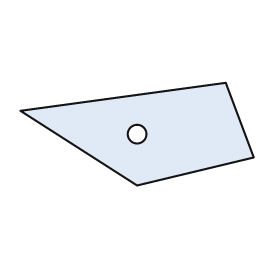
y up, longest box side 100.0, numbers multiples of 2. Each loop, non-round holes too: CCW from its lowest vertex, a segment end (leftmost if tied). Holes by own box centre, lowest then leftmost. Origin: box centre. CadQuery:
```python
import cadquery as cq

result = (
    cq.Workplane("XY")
    .moveTo(0.0, -22.0)
    .lineTo(50.0, -10.0)
    .lineTo(38.0, 22.0)
    .lineTo(-50.0, 10.0)
    .close()
    .moveTo(0.0, 0.0)
    .circle(4.0)
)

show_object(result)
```